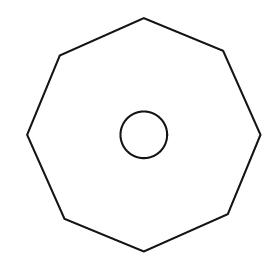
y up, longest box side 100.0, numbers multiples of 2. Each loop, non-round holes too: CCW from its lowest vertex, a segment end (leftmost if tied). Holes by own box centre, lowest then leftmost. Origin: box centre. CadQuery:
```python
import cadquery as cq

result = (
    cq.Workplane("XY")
    .moveTo(0.0, -50.0)
    .lineTo(36.0, -34.0)
    .lineTo(50.0, 0.0)
    .lineTo(34.0, 36.0)
    .lineTo(0.0, 50.0)
    .lineTo(-36.0, 34.0)
    .lineTo(-50.0, 0.0)
    .lineTo(-34.0, -36.0)
    .close()
    .moveTo(0.0, 0.0)
    .circle(10.0)
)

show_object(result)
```